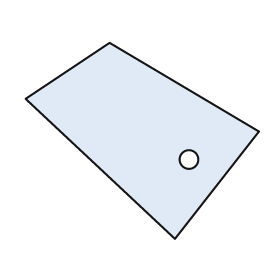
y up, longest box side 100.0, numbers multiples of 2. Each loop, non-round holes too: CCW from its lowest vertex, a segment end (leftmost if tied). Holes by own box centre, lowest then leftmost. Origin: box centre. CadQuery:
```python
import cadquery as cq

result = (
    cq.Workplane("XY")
    .moveTo(14.0, -42.0)
    .lineTo(50.0, 4.0)
    .lineTo(-14.0, 42.0)
    .lineTo(-50.0, 18.0)
    .close()
    .moveTo(20.0, -8.0)
    .circle(4.0)
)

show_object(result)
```